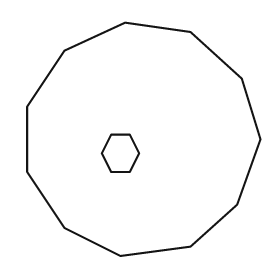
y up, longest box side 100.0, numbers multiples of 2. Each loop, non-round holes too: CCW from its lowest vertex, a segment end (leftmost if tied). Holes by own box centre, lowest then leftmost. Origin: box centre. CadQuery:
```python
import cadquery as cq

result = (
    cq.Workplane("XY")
    .moveTo(-10.0, -50.0)
    .lineTo(20.0, -46.0)
    .lineTo(40.0, -28.0)
    .lineTo(50.0, 0.0)
    .lineTo(42.0, 26.0)
    .lineTo(20.0, 46.0)
    .lineTo(-8.0, 50.0)
    .lineTo(-34.0, 38.0)
    .lineTo(-50.0, 14.0)
    .lineTo(-50.0, -14.0)
    .lineTo(-34.0, -38.0)
    .close()
    .moveTo(-14.0, -14.0)
    .lineTo(-6.0, -14.0)
    .lineTo(-2.0, -6.0)
    .lineTo(-6.0, 2.0)
    .lineTo(-14.0, 2.0)
    .lineTo(-18.0, -6.0)
    .close()
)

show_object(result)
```